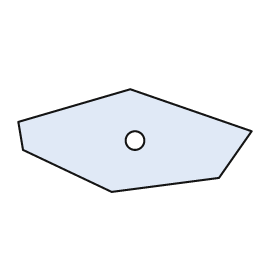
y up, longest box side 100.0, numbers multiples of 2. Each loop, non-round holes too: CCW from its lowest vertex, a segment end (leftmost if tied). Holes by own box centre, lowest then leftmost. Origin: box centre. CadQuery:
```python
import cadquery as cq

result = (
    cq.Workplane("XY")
    .moveTo(-10.0, -22.0)
    .lineTo(36.0, -16.0)
    .lineTo(50.0, 4.0)
    .lineTo(-2.0, 22.0)
    .lineTo(-50.0, 8.0)
    .lineTo(-48.0, -4.0)
    .close()
    .moveTo(0.0, 0.0)
    .circle(4.0)
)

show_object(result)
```